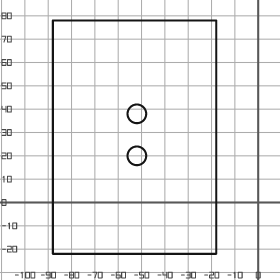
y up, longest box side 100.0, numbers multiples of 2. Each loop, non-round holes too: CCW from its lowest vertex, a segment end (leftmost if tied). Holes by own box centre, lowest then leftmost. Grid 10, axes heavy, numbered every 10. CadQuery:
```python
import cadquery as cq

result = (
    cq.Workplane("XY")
    .moveTo(-88.0, -22.0)
    .lineTo(-18.0, -22.0)
    .lineTo(-18.0, 78.0)
    .lineTo(-88.0, 78.0)
    .close()
    .moveTo(-52.0, 20.0)
    .circle(4.0)
    .moveTo(-52.0, 38.0)
    .circle(4.0)
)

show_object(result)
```